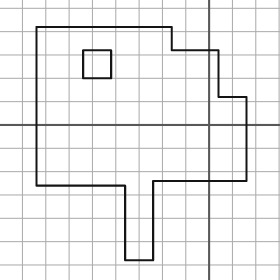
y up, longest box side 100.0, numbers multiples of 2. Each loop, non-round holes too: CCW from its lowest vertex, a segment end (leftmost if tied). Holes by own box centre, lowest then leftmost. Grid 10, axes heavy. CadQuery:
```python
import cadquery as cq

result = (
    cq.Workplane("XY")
    .moveTo(-36.0, -58.0)
    .lineTo(-24.0, -58.0)
    .lineTo(-24.0, -24.0)
    .lineTo(16.0, -24.0)
    .lineTo(16.0, 12.0)
    .lineTo(4.0, 12.0)
    .lineTo(4.0, 32.0)
    .lineTo(-16.0, 32.0)
    .lineTo(-16.0, 42.0)
    .lineTo(-74.0, 42.0)
    .lineTo(-74.0, -26.0)
    .lineTo(-36.0, -26.0)
    .close()
    .moveTo(-54.0, 20.0)
    .lineTo(-42.0, 20.0)
    .lineTo(-42.0, 32.0)
    .lineTo(-54.0, 32.0)
    .close()
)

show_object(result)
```